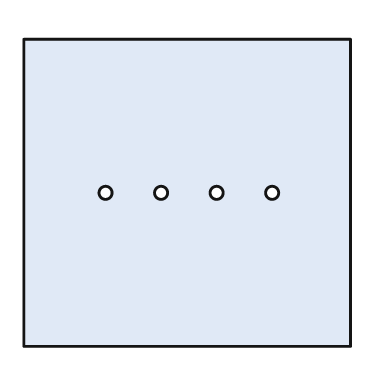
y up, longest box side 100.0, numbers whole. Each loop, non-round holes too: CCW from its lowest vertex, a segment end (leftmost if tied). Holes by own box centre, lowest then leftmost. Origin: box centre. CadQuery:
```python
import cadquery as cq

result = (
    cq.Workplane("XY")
    .moveTo(-50.0, -47.0)
    .lineTo(50.0, -47.0)
    .lineTo(50.0, 47.0)
    .lineTo(-50.0, 47.0)
    .close()
    .moveTo(-25.0, 0.0)
    .circle(2.0)
    .moveTo(-8.0, 0.0)
    .circle(2.0)
    .moveTo(9.0, 0.0)
    .circle(2.0)
    .moveTo(26.0, 0.0)
    .circle(2.0)
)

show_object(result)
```